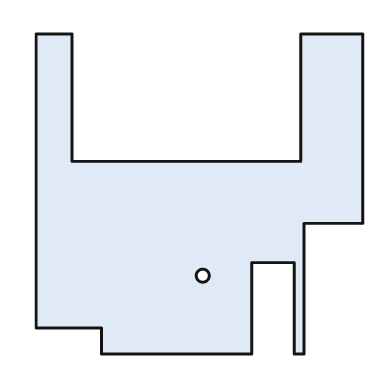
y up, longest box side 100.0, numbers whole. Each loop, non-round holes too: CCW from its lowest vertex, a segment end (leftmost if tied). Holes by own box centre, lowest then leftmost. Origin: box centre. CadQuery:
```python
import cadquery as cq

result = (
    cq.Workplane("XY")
    .moveTo(-30.0, -49.0)
    .lineTo(16.0, -49.0)
    .lineTo(16.0, -21.0)
    .lineTo(29.0, -21.0)
    .lineTo(29.0, -49.0)
    .lineTo(32.0, -49.0)
    .lineTo(32.0, -9.0)
    .lineTo(50.0, -9.0)
    .lineTo(50.0, 49.0)
    .lineTo(31.0, 49.0)
    .lineTo(31.0, 10.0)
    .lineTo(-39.0, 10.0)
    .lineTo(-39.0, 49.0)
    .lineTo(-50.0, 49.0)
    .lineTo(-50.0, -41.0)
    .lineTo(-30.0, -41.0)
    .close()
    .moveTo(1.0, -25.0)
    .circle(2.0)
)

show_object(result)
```